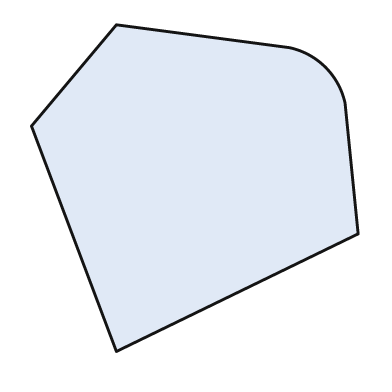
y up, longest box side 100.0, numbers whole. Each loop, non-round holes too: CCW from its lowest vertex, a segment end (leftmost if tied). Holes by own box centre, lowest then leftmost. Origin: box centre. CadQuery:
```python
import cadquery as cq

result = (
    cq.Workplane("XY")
    .moveTo(-24.0, -50.0)
    .lineTo(50.0, -14.0)
    .lineTo(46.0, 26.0)
    .threePointArc((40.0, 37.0), (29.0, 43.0))
    .lineTo(-24.0, 50.0)
    .lineTo(-50.0, 19.0)
    .close()
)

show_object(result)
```